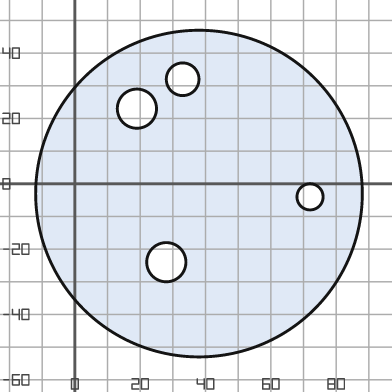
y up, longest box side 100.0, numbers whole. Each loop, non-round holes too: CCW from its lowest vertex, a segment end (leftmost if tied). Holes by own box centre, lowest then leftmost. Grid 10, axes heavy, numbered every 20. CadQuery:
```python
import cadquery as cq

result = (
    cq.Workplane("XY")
    .moveTo(38.0, -3.0)
    .circle(50.0)
    .moveTo(28.0, -24.0)
    .circle(6.0)
    .moveTo(72.0, -4.0)
    .circle(4.0)
    .moveTo(19.0, 23.0)
    .circle(6.0)
    .moveTo(33.0, 32.0)
    .circle(5.0)
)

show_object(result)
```